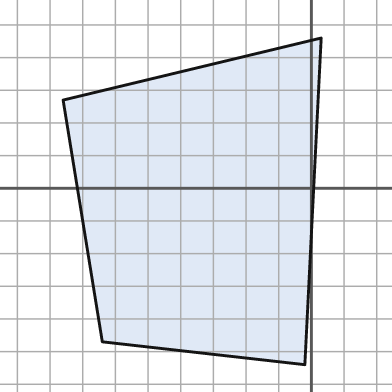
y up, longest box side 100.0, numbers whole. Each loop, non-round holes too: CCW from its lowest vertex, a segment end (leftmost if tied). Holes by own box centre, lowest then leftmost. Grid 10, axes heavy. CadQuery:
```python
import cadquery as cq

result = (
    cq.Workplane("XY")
    .moveTo(-2.0, -54.0)
    .lineTo(3.0, 46.0)
    .lineTo(-76.0, 27.0)
    .lineTo(-64.0, -47.0)
    .close()
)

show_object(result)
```